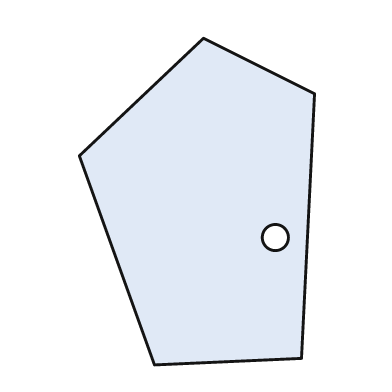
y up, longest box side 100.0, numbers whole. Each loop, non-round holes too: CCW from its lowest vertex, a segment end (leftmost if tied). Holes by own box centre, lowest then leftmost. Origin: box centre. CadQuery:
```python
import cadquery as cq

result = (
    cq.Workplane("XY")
    .moveTo(-13.0, -50.0)
    .lineTo(32.0, -48.0)
    .lineTo(36.0, 33.0)
    .lineTo(2.0, 50.0)
    .lineTo(-36.0, 14.0)
    .close()
    .moveTo(24.0, -11.0)
    .circle(4.0)
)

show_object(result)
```